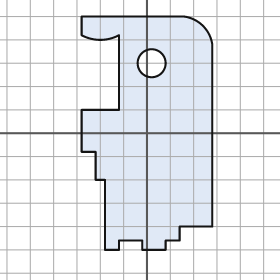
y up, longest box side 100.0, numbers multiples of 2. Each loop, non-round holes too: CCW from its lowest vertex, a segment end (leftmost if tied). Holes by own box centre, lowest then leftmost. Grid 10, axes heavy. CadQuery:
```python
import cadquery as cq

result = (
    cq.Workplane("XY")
    .moveTo(-18.0, -50.0)
    .lineTo(-12.0, -50.0)
    .lineTo(-12.0, -46.0)
    .lineTo(-2.0, -46.0)
    .lineTo(-2.0, -50.0)
    .lineTo(8.0, -50.0)
    .lineTo(8.0, -46.0)
    .lineTo(14.0, -46.0)
    .lineTo(14.0, -40.0)
    .lineTo(28.0, -40.0)
    .lineTo(28.0, 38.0)
    .threePointArc((24.0, 46.0), (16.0, 50.0))
    .lineTo(-28.0, 50.0)
    .lineTo(-28.0, 42.0)
    .threePointArc((-20.0, 40.0), (-12.0, 42.0))
    .lineTo(-12.0, 10.0)
    .lineTo(-28.0, 10.0)
    .lineTo(-28.0, -8.0)
    .lineTo(-22.0, -8.0)
    .lineTo(-22.0, -20.0)
    .lineTo(-18.0, -20.0)
    .close()
    .moveTo(2.0, 30.0)
    .circle(6.0)
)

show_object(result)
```